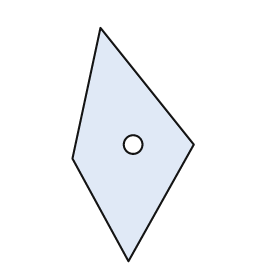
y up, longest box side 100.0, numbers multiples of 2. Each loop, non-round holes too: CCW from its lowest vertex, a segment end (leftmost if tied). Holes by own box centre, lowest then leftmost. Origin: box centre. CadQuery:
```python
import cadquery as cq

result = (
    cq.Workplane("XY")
    .moveTo(-2.0, -50.0)
    .lineTo(26.0, 0.0)
    .lineTo(-14.0, 50.0)
    .lineTo(-26.0, -6.0)
    .close()
    .moveTo(0.0, 0.0)
    .circle(4.0)
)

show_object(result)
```